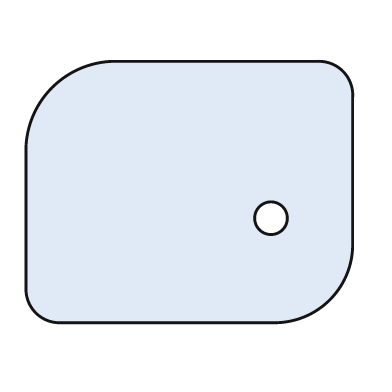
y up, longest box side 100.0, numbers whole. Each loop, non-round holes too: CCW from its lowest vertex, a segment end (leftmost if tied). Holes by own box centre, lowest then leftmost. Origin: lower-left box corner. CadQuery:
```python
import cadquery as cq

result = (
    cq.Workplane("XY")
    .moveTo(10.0, 0.0)
    .lineTo(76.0, 0.0)
    .threePointArc((93.0, 7.0), (100.0, 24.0))
    .lineTo(100.0, 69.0)
    .threePointArc((97.0, 77.0), (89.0, 80.0))
    .lineTo(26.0, 80.0)
    .threePointArc((8.0, 72.0), (0.0, 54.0))
    .lineTo(0.0, 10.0)
    .threePointArc((3.0, 3.0), (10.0, 0.0))
    .close()
    .moveTo(75.0, 32.0)
    .circle(5.0)
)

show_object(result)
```